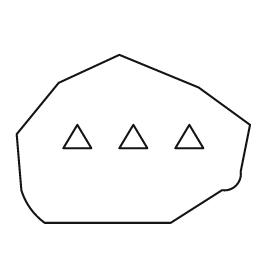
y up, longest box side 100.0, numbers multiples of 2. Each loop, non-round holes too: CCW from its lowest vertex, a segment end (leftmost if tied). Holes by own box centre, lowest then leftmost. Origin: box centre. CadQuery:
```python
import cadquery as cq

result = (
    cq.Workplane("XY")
    .moveTo(-38.0, -36.0)
    .lineTo(16.0, -36.0)
    .lineTo(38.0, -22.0)
    .threePointArc((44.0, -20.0), (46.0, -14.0))
    .lineTo(50.0, 6.0)
    .lineTo(28.0, 22.0)
    .lineTo(-6.0, 36.0)
    .lineTo(-32.0, 24.0)
    .lineTo(-50.0, 2.0)
    .lineTo(-48.0, -22.0)
    .threePointArc((-44.0, -30.0), (-38.0, -36.0))
    .close()
    .moveTo(-30.0, -4.0)
    .lineTo(-18.0, -4.0)
    .lineTo(-24.0, 6.0)
    .close()
    .moveTo(-6.0, -4.0)
    .lineTo(6.0, -4.0)
    .lineTo(0.0, 6.0)
    .close()
    .moveTo(18.0, -4.0)
    .lineTo(30.0, -4.0)
    .lineTo(24.0, 6.0)
    .close()
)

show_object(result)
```